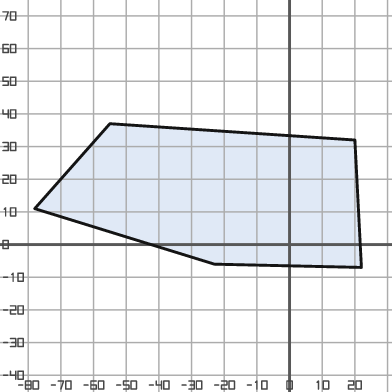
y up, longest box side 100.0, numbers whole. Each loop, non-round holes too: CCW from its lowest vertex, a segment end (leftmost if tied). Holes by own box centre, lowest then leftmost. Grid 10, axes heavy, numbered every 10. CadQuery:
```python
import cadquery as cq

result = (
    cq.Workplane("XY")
    .moveTo(22.0, -7.0)
    .lineTo(20.0, 32.0)
    .lineTo(-55.0, 37.0)
    .lineTo(-78.0, 11.0)
    .lineTo(-23.0, -6.0)
    .close()
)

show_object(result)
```